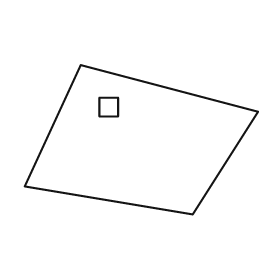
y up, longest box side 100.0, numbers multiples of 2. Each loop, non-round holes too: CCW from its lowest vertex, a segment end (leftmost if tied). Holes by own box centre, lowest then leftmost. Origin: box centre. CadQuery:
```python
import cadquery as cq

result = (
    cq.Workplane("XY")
    .moveTo(22.0, -32.0)
    .lineTo(50.0, 12.0)
    .lineTo(-26.0, 32.0)
    .lineTo(-50.0, -20.0)
    .close()
    .moveTo(-18.0, 10.0)
    .lineTo(-10.0, 10.0)
    .lineTo(-10.0, 18.0)
    .lineTo(-18.0, 18.0)
    .close()
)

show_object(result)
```